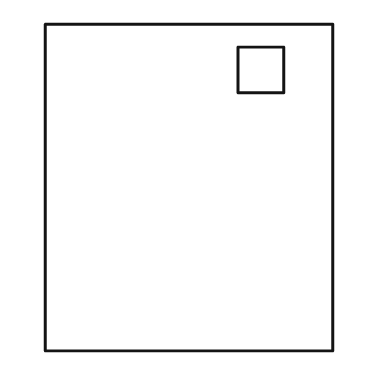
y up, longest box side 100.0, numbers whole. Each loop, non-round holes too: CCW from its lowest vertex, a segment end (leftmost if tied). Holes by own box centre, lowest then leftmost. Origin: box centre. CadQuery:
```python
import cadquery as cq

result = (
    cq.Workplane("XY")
    .moveTo(-44.0, -50.0)
    .lineTo(44.0, -50.0)
    .lineTo(44.0, 50.0)
    .lineTo(-44.0, 50.0)
    .close()
    .moveTo(15.0, 29.0)
    .lineTo(29.0, 29.0)
    .lineTo(29.0, 43.0)
    .lineTo(15.0, 43.0)
    .close()
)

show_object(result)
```